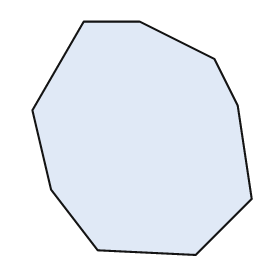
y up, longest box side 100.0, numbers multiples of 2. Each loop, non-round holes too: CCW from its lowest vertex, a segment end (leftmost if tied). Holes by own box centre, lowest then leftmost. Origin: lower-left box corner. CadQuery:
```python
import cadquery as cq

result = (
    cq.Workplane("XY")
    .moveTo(70.0, 0.0)
    .lineTo(94.0, 24.0)
    .lineTo(88.0, 64.0)
    .lineTo(78.0, 84.0)
    .lineTo(46.0, 100.0)
    .lineTo(22.0, 100.0)
    .lineTo(0.0, 62.0)
    .lineTo(8.0, 28.0)
    .lineTo(28.0, 2.0)
    .close()
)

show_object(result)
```